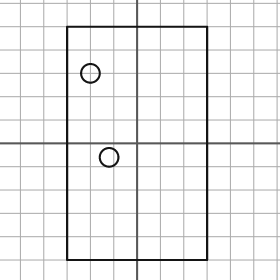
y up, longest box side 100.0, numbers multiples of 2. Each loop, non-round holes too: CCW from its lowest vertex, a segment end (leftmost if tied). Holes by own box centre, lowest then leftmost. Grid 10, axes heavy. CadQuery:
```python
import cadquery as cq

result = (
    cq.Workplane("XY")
    .moveTo(-30.0, -50.0)
    .lineTo(30.0, -50.0)
    .lineTo(30.0, 50.0)
    .lineTo(-30.0, 50.0)
    .close()
    .moveTo(-12.0, -6.0)
    .circle(4.0)
    .moveTo(-20.0, 30.0)
    .circle(4.0)
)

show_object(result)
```